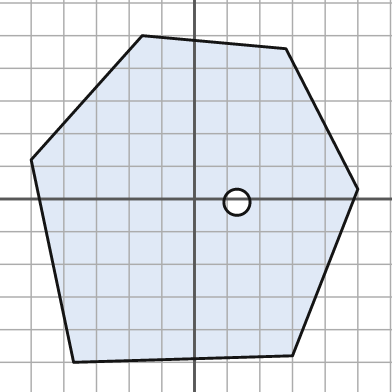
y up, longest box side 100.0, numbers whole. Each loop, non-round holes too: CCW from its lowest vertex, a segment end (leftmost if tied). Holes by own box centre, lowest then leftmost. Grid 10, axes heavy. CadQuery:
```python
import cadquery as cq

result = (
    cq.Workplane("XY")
    .moveTo(-37.0, -50.0)
    .lineTo(30.0, -48.0)
    .lineTo(50.0, 3.0)
    .lineTo(28.0, 46.0)
    .lineTo(-16.0, 50.0)
    .lineTo(-50.0, 12.0)
    .close()
    .moveTo(13.0, -1.0)
    .circle(4.0)
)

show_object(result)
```